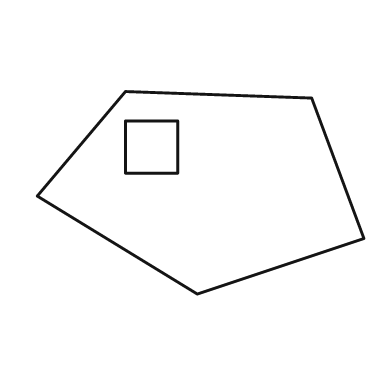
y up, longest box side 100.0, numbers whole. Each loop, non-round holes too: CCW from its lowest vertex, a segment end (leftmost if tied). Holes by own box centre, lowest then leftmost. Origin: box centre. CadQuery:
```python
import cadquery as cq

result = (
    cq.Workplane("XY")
    .moveTo(-1.0, -31.0)
    .lineTo(50.0, -14.0)
    .lineTo(34.0, 29.0)
    .lineTo(-23.0, 31.0)
    .lineTo(-50.0, -1.0)
    .close()
    .moveTo(-23.0, 6.0)
    .lineTo(-7.0, 6.0)
    .lineTo(-7.0, 22.0)
    .lineTo(-23.0, 22.0)
    .close()
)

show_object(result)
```